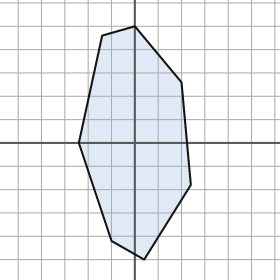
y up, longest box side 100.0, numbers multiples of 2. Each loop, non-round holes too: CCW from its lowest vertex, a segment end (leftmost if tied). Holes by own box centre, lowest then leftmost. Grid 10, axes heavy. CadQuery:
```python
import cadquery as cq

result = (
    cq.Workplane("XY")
    .moveTo(4.0, -50.0)
    .lineTo(24.0, -18.0)
    .lineTo(20.0, 26.0)
    .lineTo(0.0, 50.0)
    .lineTo(-14.0, 46.0)
    .lineTo(-24.0, 0.0)
    .lineTo(-10.0, -42.0)
    .close()
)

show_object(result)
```